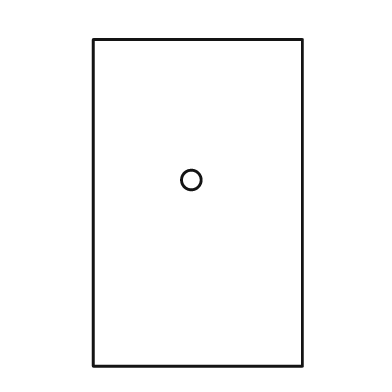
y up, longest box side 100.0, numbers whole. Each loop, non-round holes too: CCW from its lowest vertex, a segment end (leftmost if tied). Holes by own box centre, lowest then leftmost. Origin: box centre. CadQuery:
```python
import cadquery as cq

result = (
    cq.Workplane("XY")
    .moveTo(-32.0, -50.0)
    .lineTo(32.0, -50.0)
    .lineTo(32.0, 50.0)
    .lineTo(-32.0, 50.0)
    .close()
    .moveTo(-2.0, 7.0)
    .circle(3.0)
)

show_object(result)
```